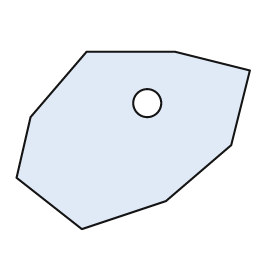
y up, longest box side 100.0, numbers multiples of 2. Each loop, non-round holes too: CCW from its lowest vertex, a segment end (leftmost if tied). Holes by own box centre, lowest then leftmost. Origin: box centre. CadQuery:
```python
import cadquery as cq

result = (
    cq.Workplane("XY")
    .moveTo(-22.0, -38.0)
    .lineTo(14.0, -26.0)
    .lineTo(42.0, -2.0)
    .lineTo(50.0, 30.0)
    .lineTo(18.0, 38.0)
    .lineTo(-20.0, 38.0)
    .lineTo(-44.0, 10.0)
    .lineTo(-50.0, -16.0)
    .close()
    .moveTo(6.0, 16.0)
    .circle(6.0)
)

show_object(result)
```